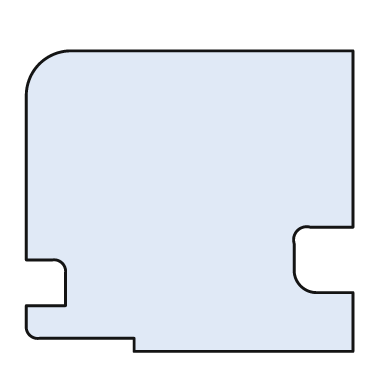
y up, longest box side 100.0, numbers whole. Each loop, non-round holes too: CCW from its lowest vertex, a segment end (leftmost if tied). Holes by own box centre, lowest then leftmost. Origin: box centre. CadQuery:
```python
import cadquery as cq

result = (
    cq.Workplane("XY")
    .moveTo(-17.0, -46.0)
    .lineTo(50.0, -46.0)
    .lineTo(50.0, -28.0)
    .lineTo(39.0, -28.0)
    .threePointArc((34.0, -26.0), (32.0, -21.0))
    .lineTo(32.0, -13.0)
    .threePointArc((33.0, -9.0), (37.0, -8.0))
    .lineTo(50.0, -8.0)
    .lineTo(50.0, 46.0)
    .lineTo(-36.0, 46.0)
    .threePointArc((-46.0, 42.0), (-50.0, 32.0))
    .lineTo(-50.0, -18.0)
    .lineTo(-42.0, -18.0)
    .threePointArc((-39.0, -19.0), (-38.0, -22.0))
    .lineTo(-38.0, -32.0)
    .lineTo(-50.0, -32.0)
    .lineTo(-50.0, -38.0)
    .threePointArc((-49.0, -41.0), (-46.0, -42.0))
    .lineTo(-17.0, -42.0)
    .close()
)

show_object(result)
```